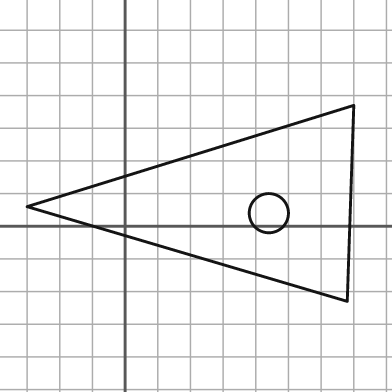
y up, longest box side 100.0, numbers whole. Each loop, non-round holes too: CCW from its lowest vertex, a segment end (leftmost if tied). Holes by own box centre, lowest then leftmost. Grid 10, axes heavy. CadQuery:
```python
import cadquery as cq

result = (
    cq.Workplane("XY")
    .moveTo(68.0, -23.0)
    .lineTo(70.0, 37.0)
    .lineTo(-30.0, 6.0)
    .close()
    .moveTo(44.0, 4.0)
    .circle(6.0)
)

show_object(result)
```